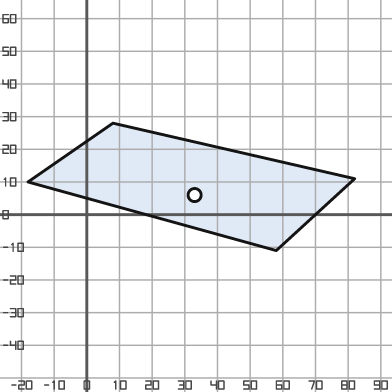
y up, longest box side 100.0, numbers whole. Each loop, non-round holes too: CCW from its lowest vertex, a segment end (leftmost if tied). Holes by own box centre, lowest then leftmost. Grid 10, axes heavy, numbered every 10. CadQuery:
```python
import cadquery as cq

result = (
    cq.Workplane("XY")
    .moveTo(58.0, -11.0)
    .lineTo(82.0, 11.0)
    .lineTo(8.0, 28.0)
    .lineTo(-18.0, 10.0)
    .close()
    .moveTo(33.0, 6.0)
    .circle(2.0)
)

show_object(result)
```